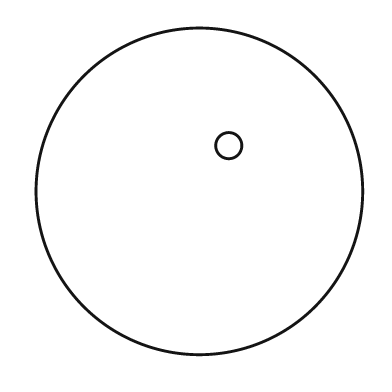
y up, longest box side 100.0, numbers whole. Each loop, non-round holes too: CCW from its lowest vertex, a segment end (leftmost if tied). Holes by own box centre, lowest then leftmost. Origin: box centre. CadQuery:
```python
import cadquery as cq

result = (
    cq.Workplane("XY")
    .moveTo(0.0, 0.0)
    .circle(50.0)
    .moveTo(9.0, 14.0)
    .circle(4.0)
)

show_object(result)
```